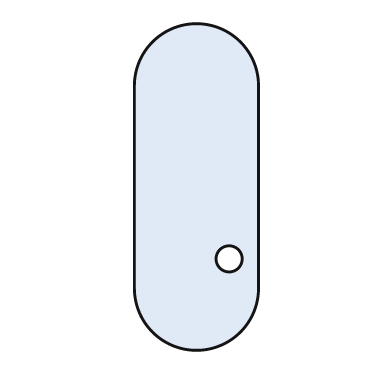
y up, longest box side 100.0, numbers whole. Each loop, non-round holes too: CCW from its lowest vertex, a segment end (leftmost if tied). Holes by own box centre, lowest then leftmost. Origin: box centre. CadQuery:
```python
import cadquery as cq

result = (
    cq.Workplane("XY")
    .moveTo(-19.0, -31.0)
    .threePointArc((0.0, -50.0), (19.0, -31.0))
    .lineTo(19.0, 31.0)
    .threePointArc((0.0, 50.0), (-19.0, 31.0))
    .close()
    .moveTo(10.0, -22.0)
    .circle(4.0)
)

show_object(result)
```